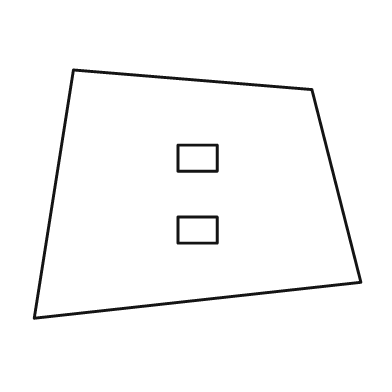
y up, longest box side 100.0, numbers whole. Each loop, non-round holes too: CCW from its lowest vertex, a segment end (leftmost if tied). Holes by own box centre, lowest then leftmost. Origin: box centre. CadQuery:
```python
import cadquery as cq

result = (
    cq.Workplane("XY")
    .moveTo(-50.0, -38.0)
    .lineTo(50.0, -27.0)
    .lineTo(35.0, 32.0)
    .lineTo(-38.0, 38.0)
    .close()
    .moveTo(-6.0, -15.0)
    .lineTo(6.0, -15.0)
    .lineTo(6.0, -7.0)
    .lineTo(-6.0, -7.0)
    .close()
    .moveTo(-6.0, 7.0)
    .lineTo(6.0, 7.0)
    .lineTo(6.0, 15.0)
    .lineTo(-6.0, 15.0)
    .close()
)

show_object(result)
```